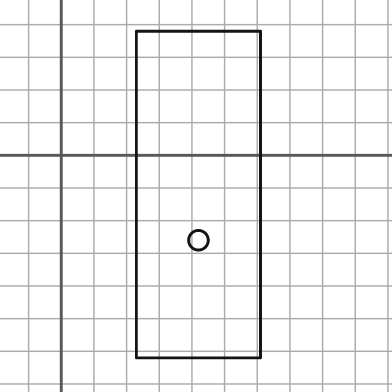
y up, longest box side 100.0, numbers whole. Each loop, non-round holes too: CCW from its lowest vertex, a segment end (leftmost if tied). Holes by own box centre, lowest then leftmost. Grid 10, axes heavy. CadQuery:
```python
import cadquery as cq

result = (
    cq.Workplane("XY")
    .moveTo(23.0, -62.0)
    .lineTo(61.0, -62.0)
    .lineTo(61.0, 38.0)
    .lineTo(23.0, 38.0)
    .close()
    .moveTo(42.0, -26.0)
    .circle(3.0)
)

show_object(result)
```